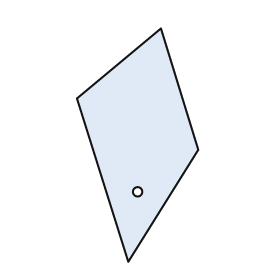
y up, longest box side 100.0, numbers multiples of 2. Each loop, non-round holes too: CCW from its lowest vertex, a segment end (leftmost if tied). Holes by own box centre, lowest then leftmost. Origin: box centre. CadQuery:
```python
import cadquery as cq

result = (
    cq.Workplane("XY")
    .moveTo(-4.0, -50.0)
    .lineTo(26.0, -2.0)
    .lineTo(10.0, 50.0)
    .lineTo(-26.0, 20.0)
    .close()
    .moveTo(0.0, -20.0)
    .circle(2.0)
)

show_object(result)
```